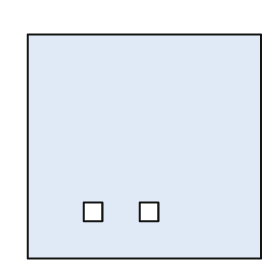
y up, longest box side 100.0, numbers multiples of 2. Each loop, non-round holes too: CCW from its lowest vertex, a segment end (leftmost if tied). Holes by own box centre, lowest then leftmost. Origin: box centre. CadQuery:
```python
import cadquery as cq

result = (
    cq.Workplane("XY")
    .moveTo(-50.0, -48.0)
    .lineTo(50.0, -48.0)
    .lineTo(50.0, 48.0)
    .lineTo(-50.0, 48.0)
    .close()
    .moveTo(-26.0, -32.0)
    .lineTo(-18.0, -32.0)
    .lineTo(-18.0, -24.0)
    .lineTo(-26.0, -24.0)
    .close()
    .moveTo(-2.0, -32.0)
    .lineTo(6.0, -32.0)
    .lineTo(6.0, -24.0)
    .lineTo(-2.0, -24.0)
    .close()
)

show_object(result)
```